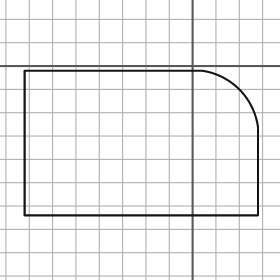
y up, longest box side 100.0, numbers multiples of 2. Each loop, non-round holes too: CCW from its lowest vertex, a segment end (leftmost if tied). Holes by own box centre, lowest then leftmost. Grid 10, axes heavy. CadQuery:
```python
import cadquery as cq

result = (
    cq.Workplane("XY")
    .moveTo(-72.0, -64.0)
    .lineTo(28.0, -64.0)
    .lineTo(28.0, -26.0)
    .threePointArc((20.0, -10.0), (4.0, -2.0))
    .lineTo(-72.0, -2.0)
    .close()
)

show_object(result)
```